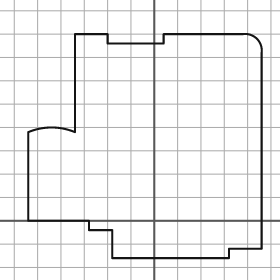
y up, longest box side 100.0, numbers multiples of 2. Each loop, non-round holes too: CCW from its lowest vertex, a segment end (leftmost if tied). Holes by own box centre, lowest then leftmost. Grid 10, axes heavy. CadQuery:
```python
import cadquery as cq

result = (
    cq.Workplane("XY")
    .moveTo(-18.0, -16.0)
    .lineTo(32.0, -16.0)
    .lineTo(32.0, -12.0)
    .lineTo(46.0, -12.0)
    .lineTo(46.0, 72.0)
    .threePointArc((44.0, 78.0), (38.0, 80.0))
    .lineTo(4.0, 80.0)
    .lineTo(4.0, 76.0)
    .lineTo(-20.0, 76.0)
    .lineTo(-20.0, 80.0)
    .lineTo(-34.0, 80.0)
    .lineTo(-34.0, 38.0)
    .threePointArc((-44.0, 40.0), (-54.0, 38.0))
    .lineTo(-54.0, 0.0)
    .lineTo(-28.0, 0.0)
    .lineTo(-28.0, -4.0)
    .lineTo(-18.0, -4.0)
    .close()
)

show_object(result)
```